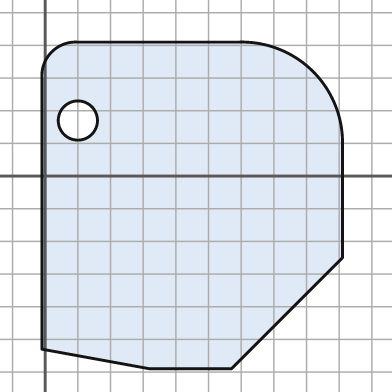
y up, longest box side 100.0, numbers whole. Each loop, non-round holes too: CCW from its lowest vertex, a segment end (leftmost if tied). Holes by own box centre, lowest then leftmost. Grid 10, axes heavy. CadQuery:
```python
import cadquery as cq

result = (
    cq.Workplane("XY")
    .moveTo(32.0, -59.0)
    .lineTo(57.0, -59.0)
    .lineTo(91.0, -25.0)
    .lineTo(91.0, 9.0)
    .threePointArc((82.0, 32.0), (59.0, 41.0))
    .lineTo(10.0, 41.0)
    .threePointArc((2.0, 38.0), (-1.0, 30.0))
    .lineTo(-1.0, -53.0)
    .close()
    .moveTo(10.0, 17.0)
    .circle(6.0)
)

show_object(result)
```